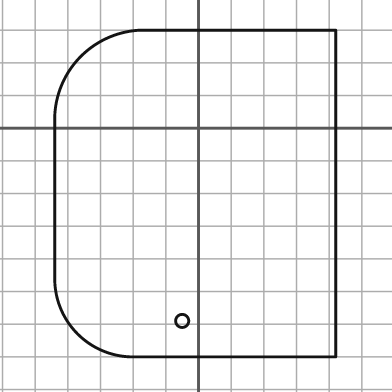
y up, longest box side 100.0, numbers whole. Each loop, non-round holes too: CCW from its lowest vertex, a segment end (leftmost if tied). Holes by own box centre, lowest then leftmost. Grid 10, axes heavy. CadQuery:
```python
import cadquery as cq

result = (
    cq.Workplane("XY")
    .moveTo(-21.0, -70.0)
    .lineTo(42.0, -70.0)
    .lineTo(42.0, 30.0)
    .lineTo(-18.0, 30.0)
    .threePointArc((-36.0, 22.0), (-44.0, 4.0))
    .lineTo(-44.0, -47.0)
    .threePointArc((-37.0, -63.0), (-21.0, -70.0))
    .close()
    .moveTo(-5.0, -59.0)
    .circle(2.0)
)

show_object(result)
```